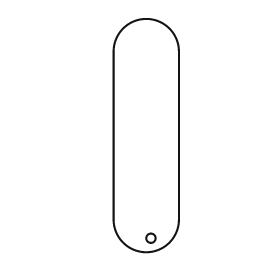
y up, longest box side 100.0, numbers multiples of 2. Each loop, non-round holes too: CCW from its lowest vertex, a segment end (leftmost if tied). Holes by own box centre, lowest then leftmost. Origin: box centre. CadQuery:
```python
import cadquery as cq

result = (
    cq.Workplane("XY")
    .moveTo(-14.0, -36.0)
    .threePointArc((0.0, -50.0), (14.0, -36.0))
    .lineTo(14.0, 36.0)
    .threePointArc((0.0, 50.0), (-14.0, 36.0))
    .close()
    .moveTo(2.0, -44.0)
    .circle(2.0)
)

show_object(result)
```